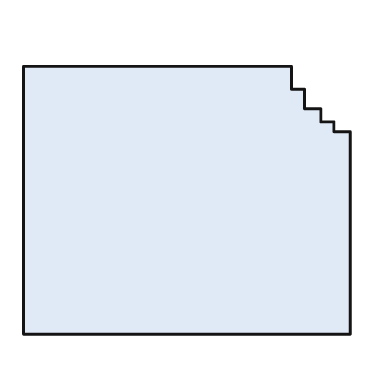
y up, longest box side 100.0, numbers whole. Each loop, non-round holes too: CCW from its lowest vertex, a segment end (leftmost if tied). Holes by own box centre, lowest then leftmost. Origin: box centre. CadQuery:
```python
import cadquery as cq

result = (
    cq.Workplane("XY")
    .moveTo(-50.0, -41.0)
    .lineTo(50.0, -41.0)
    .lineTo(50.0, 21.0)
    .lineTo(45.0, 21.0)
    .lineTo(45.0, 24.0)
    .lineTo(41.0, 24.0)
    .lineTo(41.0, 28.0)
    .lineTo(36.0, 28.0)
    .lineTo(36.0, 34.0)
    .lineTo(32.0, 34.0)
    .lineTo(32.0, 41.0)
    .lineTo(-50.0, 41.0)
    .close()
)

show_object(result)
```